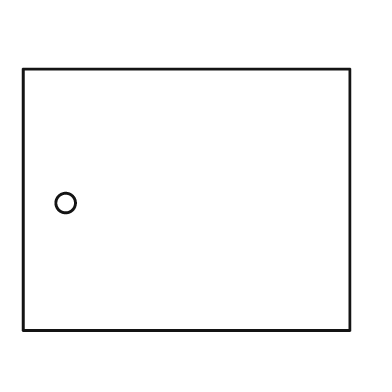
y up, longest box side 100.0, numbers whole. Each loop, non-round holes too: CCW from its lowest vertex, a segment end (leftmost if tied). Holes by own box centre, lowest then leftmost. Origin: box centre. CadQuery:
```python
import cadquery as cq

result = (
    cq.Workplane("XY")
    .moveTo(-50.0, -40.0)
    .lineTo(50.0, -40.0)
    .lineTo(50.0, 40.0)
    .lineTo(-50.0, 40.0)
    .close()
    .moveTo(-37.0, -1.0)
    .circle(3.0)
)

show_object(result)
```